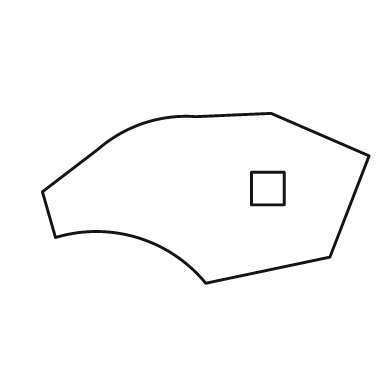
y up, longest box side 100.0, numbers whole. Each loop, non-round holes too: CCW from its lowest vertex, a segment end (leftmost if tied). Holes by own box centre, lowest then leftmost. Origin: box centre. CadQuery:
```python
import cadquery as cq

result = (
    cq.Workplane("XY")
    .moveTo(0.0, -26.0)
    .lineTo(38.0, -18.0)
    .lineTo(50.0, 13.0)
    .lineTo(20.0, 26.0)
    .lineTo(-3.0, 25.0)
    .threePointArc((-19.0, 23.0), (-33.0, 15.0))
    .lineTo(-50.0, 2.0)
    .lineTo(-46.0, -12.0)
    .threePointArc((-21.0, -12.0), (0.0, -26.0))
    .close()
    .moveTo(14.0, -2.0)
    .lineTo(24.0, -2.0)
    .lineTo(24.0, 8.0)
    .lineTo(14.0, 8.0)
    .close()
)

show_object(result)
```